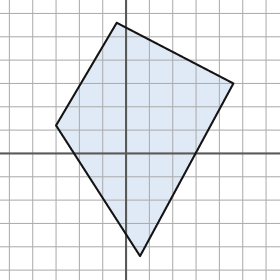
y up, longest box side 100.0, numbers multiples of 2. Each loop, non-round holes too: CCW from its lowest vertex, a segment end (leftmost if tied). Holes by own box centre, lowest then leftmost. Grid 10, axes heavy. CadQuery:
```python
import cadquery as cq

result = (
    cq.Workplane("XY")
    .moveTo(6.0, -44.0)
    .lineTo(46.0, 30.0)
    .lineTo(-4.0, 56.0)
    .lineTo(-30.0, 12.0)
    .close()
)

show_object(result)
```